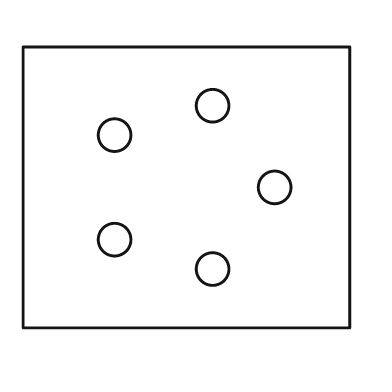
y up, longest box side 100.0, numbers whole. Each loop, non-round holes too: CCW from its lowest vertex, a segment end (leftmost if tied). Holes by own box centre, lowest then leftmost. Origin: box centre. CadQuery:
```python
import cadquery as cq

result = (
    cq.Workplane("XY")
    .moveTo(-50.0, -43.0)
    .lineTo(50.0, -43.0)
    .lineTo(50.0, 43.0)
    .lineTo(-50.0, 43.0)
    .close()
    .moveTo(8.0, -25.0)
    .circle(5.0)
    .moveTo(-22.0, -16.0)
    .circle(5.0)
    .moveTo(27.0, 0.0)
    .circle(5.0)
    .moveTo(-22.0, 16.0)
    .circle(5.0)
    .moveTo(8.0, 25.0)
    .circle(5.0)
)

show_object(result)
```